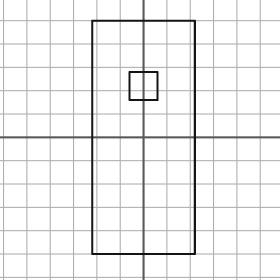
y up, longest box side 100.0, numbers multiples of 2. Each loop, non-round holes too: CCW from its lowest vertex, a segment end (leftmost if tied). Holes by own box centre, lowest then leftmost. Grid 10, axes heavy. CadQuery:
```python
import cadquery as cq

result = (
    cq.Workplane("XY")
    .moveTo(-22.0, -50.0)
    .lineTo(22.0, -50.0)
    .lineTo(22.0, 50.0)
    .lineTo(-22.0, 50.0)
    .close()
    .moveTo(-6.0, 16.0)
    .lineTo(6.0, 16.0)
    .lineTo(6.0, 28.0)
    .lineTo(-6.0, 28.0)
    .close()
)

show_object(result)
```